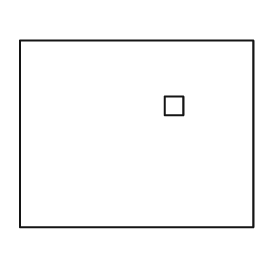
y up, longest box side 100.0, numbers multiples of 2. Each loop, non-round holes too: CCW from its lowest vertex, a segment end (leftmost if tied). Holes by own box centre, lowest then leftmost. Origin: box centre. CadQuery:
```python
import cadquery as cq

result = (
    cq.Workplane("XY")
    .moveTo(-50.0, -40.0)
    .lineTo(50.0, -40.0)
    .lineTo(50.0, 40.0)
    .lineTo(-50.0, 40.0)
    .close()
    .moveTo(12.0, 8.0)
    .lineTo(20.0, 8.0)
    .lineTo(20.0, 16.0)
    .lineTo(12.0, 16.0)
    .close()
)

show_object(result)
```